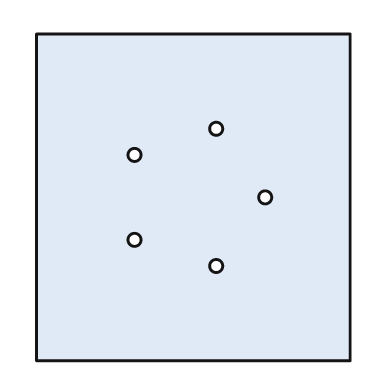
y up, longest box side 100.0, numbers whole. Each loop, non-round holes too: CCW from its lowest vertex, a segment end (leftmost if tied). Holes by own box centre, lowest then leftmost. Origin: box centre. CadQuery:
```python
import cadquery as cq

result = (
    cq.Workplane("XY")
    .moveTo(-48.0, -50.0)
    .lineTo(48.0, -50.0)
    .lineTo(48.0, 50.0)
    .lineTo(-48.0, 50.0)
    .close()
    .moveTo(7.0, -21.0)
    .circle(2.0)
    .moveTo(-18.0, -13.0)
    .circle(2.0)
    .moveTo(22.0, 0.0)
    .circle(2.0)
    .moveTo(-18.0, 13.0)
    .circle(2.0)
    .moveTo(7.0, 21.0)
    .circle(2.0)
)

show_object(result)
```